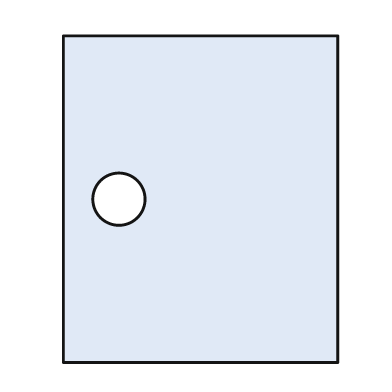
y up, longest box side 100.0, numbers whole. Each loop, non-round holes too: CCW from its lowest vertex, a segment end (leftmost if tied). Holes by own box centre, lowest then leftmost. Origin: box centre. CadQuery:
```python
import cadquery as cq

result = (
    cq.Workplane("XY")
    .moveTo(-42.0, -50.0)
    .lineTo(42.0, -50.0)
    .lineTo(42.0, 50.0)
    .lineTo(-42.0, 50.0)
    .close()
    .moveTo(-25.0, 0.0)
    .circle(8.0)
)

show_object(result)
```